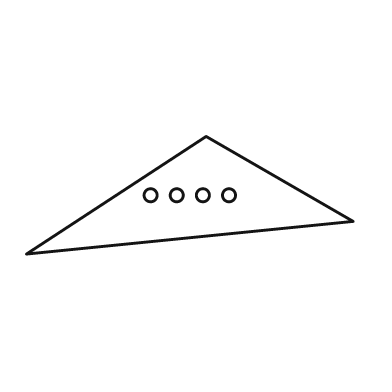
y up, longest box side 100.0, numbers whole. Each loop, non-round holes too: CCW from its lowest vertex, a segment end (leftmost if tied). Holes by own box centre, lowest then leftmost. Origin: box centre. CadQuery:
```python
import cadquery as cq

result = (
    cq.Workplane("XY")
    .moveTo(-50.0, -18.0)
    .lineTo(50.0, -8.0)
    .lineTo(5.0, 18.0)
    .close()
    .moveTo(-12.0, 0.0)
    .circle(2.0)
    .moveTo(-4.0, 0.0)
    .circle(2.0)
    .moveTo(4.0, 0.0)
    .circle(2.0)
    .moveTo(12.0, 0.0)
    .circle(2.0)
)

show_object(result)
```